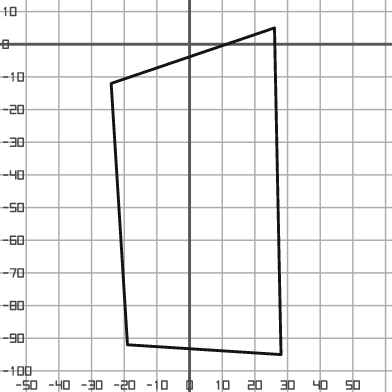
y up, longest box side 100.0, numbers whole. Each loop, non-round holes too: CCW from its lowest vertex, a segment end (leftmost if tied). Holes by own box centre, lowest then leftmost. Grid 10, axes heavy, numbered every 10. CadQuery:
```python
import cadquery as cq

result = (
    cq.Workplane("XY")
    .moveTo(28.0, -95.0)
    .lineTo(26.0, 5.0)
    .lineTo(-24.0, -12.0)
    .lineTo(-19.0, -92.0)
    .close()
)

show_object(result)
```